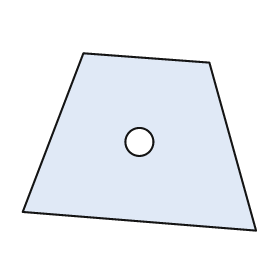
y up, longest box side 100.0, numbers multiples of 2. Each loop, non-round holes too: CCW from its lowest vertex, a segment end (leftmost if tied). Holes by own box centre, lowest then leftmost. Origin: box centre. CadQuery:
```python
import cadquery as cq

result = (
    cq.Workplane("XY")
    .moveTo(50.0, -38.0)
    .lineTo(30.0, 34.0)
    .lineTo(-24.0, 38.0)
    .lineTo(-50.0, -30.0)
    .close()
    .moveTo(0.0, 0.0)
    .circle(6.0)
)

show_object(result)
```